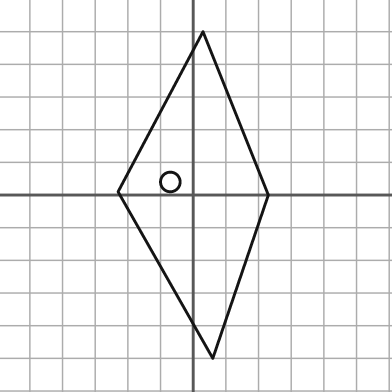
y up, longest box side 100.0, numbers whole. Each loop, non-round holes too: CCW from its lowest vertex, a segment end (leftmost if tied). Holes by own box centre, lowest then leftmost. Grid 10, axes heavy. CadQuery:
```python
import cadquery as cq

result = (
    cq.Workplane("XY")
    .moveTo(6.0, -50.0)
    .lineTo(23.0, 0.0)
    .lineTo(3.0, 50.0)
    .lineTo(-23.0, 1.0)
    .close()
    .moveTo(-7.0, 4.0)
    .circle(3.0)
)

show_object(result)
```